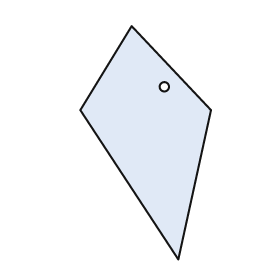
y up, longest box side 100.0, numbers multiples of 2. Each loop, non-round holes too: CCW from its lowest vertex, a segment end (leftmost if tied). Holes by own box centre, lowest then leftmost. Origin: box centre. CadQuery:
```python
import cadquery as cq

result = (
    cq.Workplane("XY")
    .moveTo(14.0, -50.0)
    .lineTo(28.0, 14.0)
    .lineTo(-6.0, 50.0)
    .lineTo(-28.0, 14.0)
    .close()
    .moveTo(8.0, 24.0)
    .circle(2.0)
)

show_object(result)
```